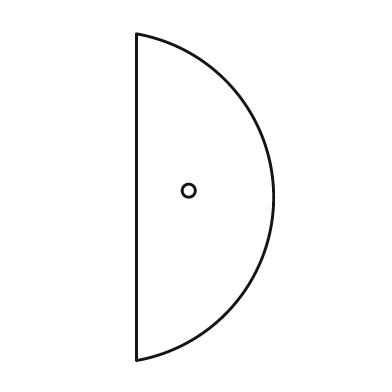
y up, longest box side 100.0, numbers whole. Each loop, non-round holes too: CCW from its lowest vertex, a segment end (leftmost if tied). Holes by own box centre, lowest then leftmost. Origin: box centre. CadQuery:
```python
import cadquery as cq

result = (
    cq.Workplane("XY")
    .moveTo(-21.0, -50.0)
    .threePointArc((21.0, 0.0), (-21.0, 50.0))
    .close()
    .moveTo(-5.0, 2.0)
    .circle(2.0)
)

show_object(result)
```